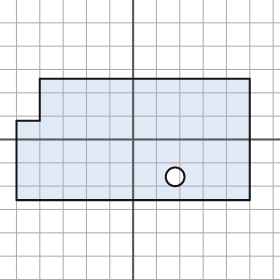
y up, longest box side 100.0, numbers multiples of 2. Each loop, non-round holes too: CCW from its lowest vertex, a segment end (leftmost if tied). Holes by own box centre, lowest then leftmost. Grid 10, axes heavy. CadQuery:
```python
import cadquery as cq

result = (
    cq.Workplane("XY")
    .moveTo(-50.0, -26.0)
    .lineTo(50.0, -26.0)
    .lineTo(50.0, 26.0)
    .lineTo(-40.0, 26.0)
    .lineTo(-40.0, 8.0)
    .lineTo(-50.0, 8.0)
    .close()
    .moveTo(18.0, -16.0)
    .circle(4.0)
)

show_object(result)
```